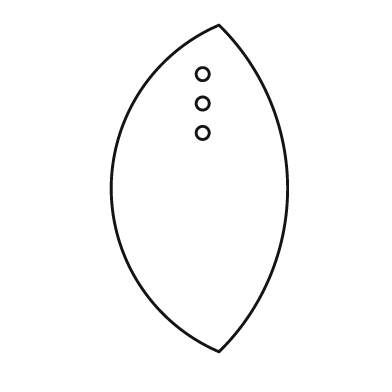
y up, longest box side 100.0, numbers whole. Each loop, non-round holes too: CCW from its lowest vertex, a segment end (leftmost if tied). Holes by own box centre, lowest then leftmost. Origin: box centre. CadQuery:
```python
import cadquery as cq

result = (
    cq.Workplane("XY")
    .moveTo(6.0, -50.0)
    .threePointArc((27.0, 0.0), (6.0, 50.0))
    .threePointArc((-27.0, 0.0), (6.0, -50.0))
    .close()
    .moveTo(1.0, 17.0)
    .circle(2.0)
    .moveTo(1.0, 26.0)
    .circle(2.0)
    .moveTo(1.0, 35.0)
    .circle(2.0)
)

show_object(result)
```